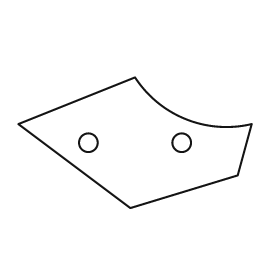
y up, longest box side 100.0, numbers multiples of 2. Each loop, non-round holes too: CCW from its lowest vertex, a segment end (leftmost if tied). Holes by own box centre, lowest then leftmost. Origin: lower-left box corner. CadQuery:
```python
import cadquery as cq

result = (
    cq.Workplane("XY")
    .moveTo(48.0, 0.0)
    .lineTo(94.0, 14.0)
    .lineTo(100.0, 36.0)
    .threePointArc((72.0, 38.0), (50.0, 56.0))
    .lineTo(0.0, 36.0)
    .close()
    .moveTo(30.0, 28.0)
    .circle(4.0)
    .moveTo(70.0, 28.0)
    .circle(4.0)
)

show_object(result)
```